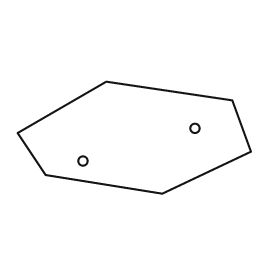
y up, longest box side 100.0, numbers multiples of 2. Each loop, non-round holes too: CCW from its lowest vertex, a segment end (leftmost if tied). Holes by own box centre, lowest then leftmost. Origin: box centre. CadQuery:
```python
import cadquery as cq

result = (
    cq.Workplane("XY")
    .moveTo(12.0, -24.0)
    .lineTo(50.0, -6.0)
    .lineTo(42.0, 16.0)
    .lineTo(-12.0, 24.0)
    .lineTo(-50.0, 2.0)
    .lineTo(-38.0, -16.0)
    .close()
    .moveTo(-22.0, -10.0)
    .circle(2.0)
    .moveTo(26.0, 4.0)
    .circle(2.0)
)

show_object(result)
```